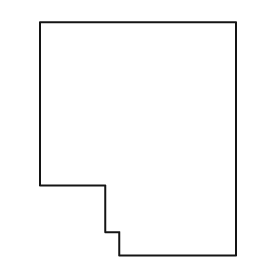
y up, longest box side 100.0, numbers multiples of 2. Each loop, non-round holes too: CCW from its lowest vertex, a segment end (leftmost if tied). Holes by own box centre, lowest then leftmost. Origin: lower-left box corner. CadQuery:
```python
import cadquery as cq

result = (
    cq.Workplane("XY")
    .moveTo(34.0, 0.0)
    .lineTo(84.0, 0.0)
    .lineTo(84.0, 100.0)
    .lineTo(0.0, 100.0)
    .lineTo(0.0, 30.0)
    .lineTo(28.0, 30.0)
    .lineTo(28.0, 10.0)
    .lineTo(34.0, 10.0)
    .close()
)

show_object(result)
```